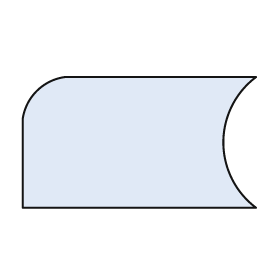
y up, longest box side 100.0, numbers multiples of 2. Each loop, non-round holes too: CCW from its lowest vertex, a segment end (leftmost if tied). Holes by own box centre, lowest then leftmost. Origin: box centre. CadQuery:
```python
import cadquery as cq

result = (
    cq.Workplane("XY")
    .moveTo(-50.0, -28.0)
    .lineTo(50.0, -28.0)
    .threePointArc((36.0, 0.0), (50.0, 28.0))
    .lineTo(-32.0, 28.0)
    .threePointArc((-44.0, 22.0), (-50.0, 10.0))
    .close()
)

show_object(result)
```